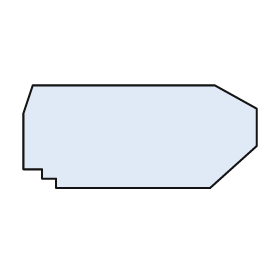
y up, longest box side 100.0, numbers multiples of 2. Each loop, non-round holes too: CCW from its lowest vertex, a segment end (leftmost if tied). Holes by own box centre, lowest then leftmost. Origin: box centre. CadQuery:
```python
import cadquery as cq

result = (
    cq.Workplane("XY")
    .moveTo(-36.0, -22.0)
    .lineTo(30.0, -22.0)
    .lineTo(50.0, -4.0)
    .lineTo(50.0, 12.0)
    .lineTo(32.0, 22.0)
    .lineTo(-46.0, 22.0)
    .lineTo(-50.0, 10.0)
    .lineTo(-50.0, -14.0)
    .lineTo(-42.0, -14.0)
    .lineTo(-42.0, -18.0)
    .lineTo(-36.0, -18.0)
    .close()
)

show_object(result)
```